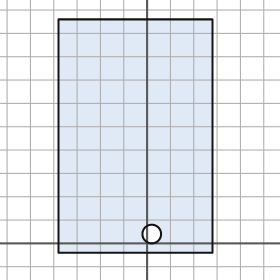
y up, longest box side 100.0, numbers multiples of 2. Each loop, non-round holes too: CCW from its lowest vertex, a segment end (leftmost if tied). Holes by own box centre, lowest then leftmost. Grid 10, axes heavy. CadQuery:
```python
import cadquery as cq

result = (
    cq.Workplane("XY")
    .moveTo(-38.0, -4.0)
    .lineTo(28.0, -4.0)
    .lineTo(28.0, 96.0)
    .lineTo(-38.0, 96.0)
    .close()
    .moveTo(2.0, 4.0)
    .circle(4.0)
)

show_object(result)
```